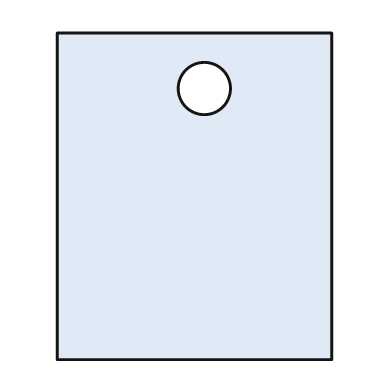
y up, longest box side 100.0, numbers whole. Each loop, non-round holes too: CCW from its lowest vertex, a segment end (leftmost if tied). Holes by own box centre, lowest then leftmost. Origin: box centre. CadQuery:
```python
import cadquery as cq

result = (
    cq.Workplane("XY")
    .moveTo(-42.0, -50.0)
    .lineTo(42.0, -50.0)
    .lineTo(42.0, 50.0)
    .lineTo(-42.0, 50.0)
    .close()
    .moveTo(3.0, 33.0)
    .circle(8.0)
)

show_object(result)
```